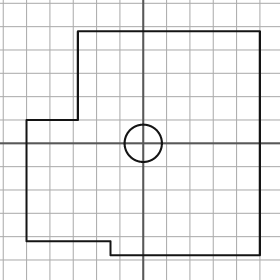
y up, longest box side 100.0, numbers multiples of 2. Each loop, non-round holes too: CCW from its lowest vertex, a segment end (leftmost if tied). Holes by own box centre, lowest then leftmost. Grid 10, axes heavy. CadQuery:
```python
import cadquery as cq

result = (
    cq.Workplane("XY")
    .moveTo(-14.0, -48.0)
    .lineTo(50.0, -48.0)
    .lineTo(50.0, 48.0)
    .lineTo(-28.0, 48.0)
    .lineTo(-28.0, 10.0)
    .lineTo(-50.0, 10.0)
    .lineTo(-50.0, -42.0)
    .lineTo(-14.0, -42.0)
    .close()
    .moveTo(0.0, 0.0)
    .circle(8.0)
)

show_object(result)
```